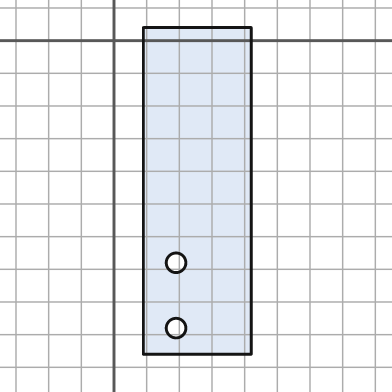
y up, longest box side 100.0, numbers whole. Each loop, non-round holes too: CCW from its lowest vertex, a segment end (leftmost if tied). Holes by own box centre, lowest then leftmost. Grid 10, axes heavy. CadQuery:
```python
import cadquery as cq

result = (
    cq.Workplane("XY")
    .moveTo(9.0, -96.0)
    .lineTo(42.0, -96.0)
    .lineTo(42.0, 4.0)
    .lineTo(9.0, 4.0)
    .close()
    .moveTo(19.0, -88.0)
    .circle(3.0)
    .moveTo(19.0, -68.0)
    .circle(3.0)
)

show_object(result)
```